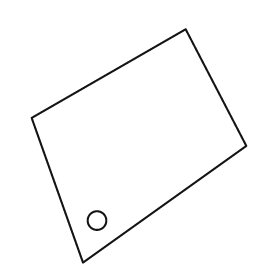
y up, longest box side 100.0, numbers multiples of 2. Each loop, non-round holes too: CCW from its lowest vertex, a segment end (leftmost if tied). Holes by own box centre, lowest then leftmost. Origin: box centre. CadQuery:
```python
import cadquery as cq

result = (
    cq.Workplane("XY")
    .moveTo(-24.0, -50.0)
    .lineTo(46.0, 0.0)
    .lineTo(20.0, 50.0)
    .lineTo(-46.0, 12.0)
    .close()
    .moveTo(-18.0, -32.0)
    .circle(4.0)
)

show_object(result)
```